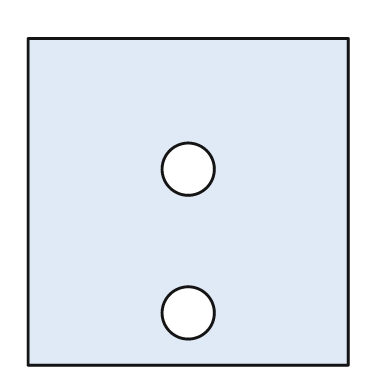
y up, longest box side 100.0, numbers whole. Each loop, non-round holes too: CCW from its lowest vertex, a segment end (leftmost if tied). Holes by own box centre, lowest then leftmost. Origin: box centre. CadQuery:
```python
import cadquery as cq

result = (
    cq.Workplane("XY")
    .moveTo(-49.0, -50.0)
    .lineTo(49.0, -50.0)
    .lineTo(49.0, 50.0)
    .lineTo(-49.0, 50.0)
    .close()
    .moveTo(0.0, -34.0)
    .circle(8.0)
    .moveTo(0.0, 10.0)
    .circle(8.0)
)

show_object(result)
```